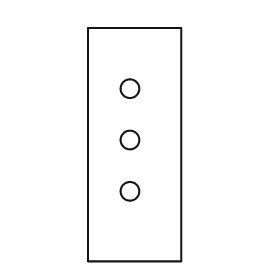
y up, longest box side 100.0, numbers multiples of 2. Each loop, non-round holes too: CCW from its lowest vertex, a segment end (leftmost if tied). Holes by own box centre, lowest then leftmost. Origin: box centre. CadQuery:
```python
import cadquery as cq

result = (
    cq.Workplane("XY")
    .moveTo(-20.0, -50.0)
    .lineTo(20.0, -50.0)
    .lineTo(20.0, 50.0)
    .lineTo(-20.0, 50.0)
    .close()
    .moveTo(-2.0, -20.0)
    .circle(4.0)
    .moveTo(-2.0, 2.0)
    .circle(4.0)
    .moveTo(-2.0, 24.0)
    .circle(4.0)
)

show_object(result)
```